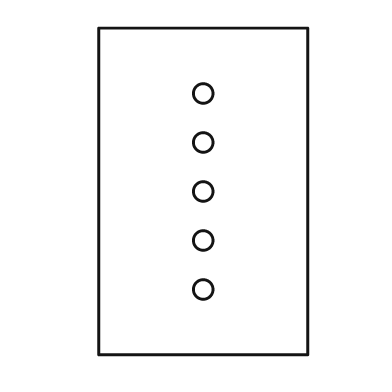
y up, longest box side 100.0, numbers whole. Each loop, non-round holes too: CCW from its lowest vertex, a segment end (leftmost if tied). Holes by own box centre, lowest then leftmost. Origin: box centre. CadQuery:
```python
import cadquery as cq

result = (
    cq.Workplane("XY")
    .moveTo(-32.0, -50.0)
    .lineTo(32.0, -50.0)
    .lineTo(32.0, 50.0)
    .lineTo(-32.0, 50.0)
    .close()
    .moveTo(0.0, -30.0)
    .circle(3.0)
    .moveTo(0.0, -15.0)
    .circle(3.0)
    .moveTo(0.0, 0.0)
    .circle(3.0)
    .moveTo(0.0, 15.0)
    .circle(3.0)
    .moveTo(0.0, 30.0)
    .circle(3.0)
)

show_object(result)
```